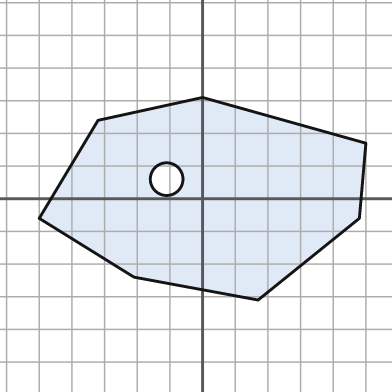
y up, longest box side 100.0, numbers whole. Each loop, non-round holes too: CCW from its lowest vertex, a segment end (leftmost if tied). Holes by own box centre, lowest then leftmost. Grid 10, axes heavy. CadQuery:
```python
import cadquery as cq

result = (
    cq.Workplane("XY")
    .moveTo(17.0, -31.0)
    .lineTo(48.0, -6.0)
    .lineTo(50.0, 17.0)
    .lineTo(0.0, 31.0)
    .lineTo(-32.0, 24.0)
    .lineTo(-50.0, -6.0)
    .lineTo(-21.0, -24.0)
    .close()
    .moveTo(-11.0, 6.0)
    .circle(5.0)
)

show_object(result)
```